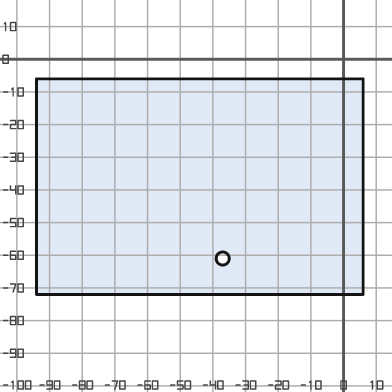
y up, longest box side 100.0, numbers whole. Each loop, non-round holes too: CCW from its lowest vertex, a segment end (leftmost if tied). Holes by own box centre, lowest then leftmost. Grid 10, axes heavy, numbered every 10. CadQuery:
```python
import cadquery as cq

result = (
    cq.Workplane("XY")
    .moveTo(-94.0, -72.0)
    .lineTo(6.0, -72.0)
    .lineTo(6.0, -6.0)
    .lineTo(-94.0, -6.0)
    .close()
    .moveTo(-37.0, -61.0)
    .circle(2.0)
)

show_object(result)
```